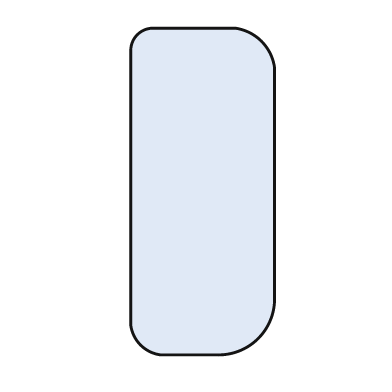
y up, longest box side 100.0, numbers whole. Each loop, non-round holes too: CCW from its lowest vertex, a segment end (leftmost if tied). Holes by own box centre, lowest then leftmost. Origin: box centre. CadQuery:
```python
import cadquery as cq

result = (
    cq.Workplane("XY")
    .moveTo(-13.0, -50.0)
    .lineTo(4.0, -50.0)
    .threePointArc((17.0, -45.0), (22.0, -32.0))
    .lineTo(22.0, 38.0)
    .threePointArc((18.0, 46.0), (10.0, 50.0))
    .lineTo(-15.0, 50.0)
    .threePointArc((-20.0, 48.0), (-22.0, 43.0))
    .lineTo(-22.0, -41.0)
    .threePointArc((-19.0, -47.0), (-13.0, -50.0))
    .close()
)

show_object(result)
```